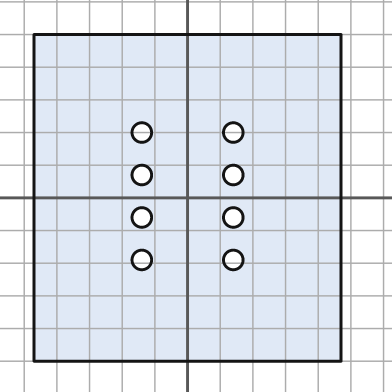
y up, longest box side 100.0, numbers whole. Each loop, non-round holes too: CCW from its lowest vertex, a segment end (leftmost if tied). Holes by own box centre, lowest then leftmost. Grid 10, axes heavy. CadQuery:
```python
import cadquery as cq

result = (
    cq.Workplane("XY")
    .moveTo(-47.0, -50.0)
    .lineTo(47.0, -50.0)
    .lineTo(47.0, 50.0)
    .lineTo(-47.0, 50.0)
    .close()
    .moveTo(-14.0, -19.0)
    .circle(3.0)
    .moveTo(14.0, -19.0)
    .circle(3.0)
    .moveTo(-14.0, -6.0)
    .circle(3.0)
    .moveTo(14.0, -6.0)
    .circle(3.0)
    .moveTo(-14.0, 7.0)
    .circle(3.0)
    .moveTo(14.0, 7.0)
    .circle(3.0)
    .moveTo(-14.0, 20.0)
    .circle(3.0)
    .moveTo(14.0, 20.0)
    .circle(3.0)
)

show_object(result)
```